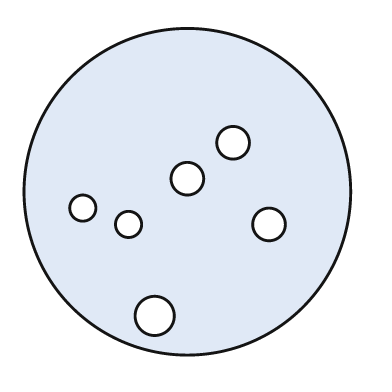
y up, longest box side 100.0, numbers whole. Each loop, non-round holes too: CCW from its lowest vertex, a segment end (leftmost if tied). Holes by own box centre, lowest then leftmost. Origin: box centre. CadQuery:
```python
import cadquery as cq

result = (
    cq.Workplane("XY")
    .moveTo(0.0, 0.0)
    .circle(50.0)
    .moveTo(-10.0, -38.0)
    .circle(6.0)
    .moveTo(-18.0, -10.0)
    .circle(4.0)
    .moveTo(25.0, -10.0)
    .circle(5.0)
    .moveTo(-32.0, -5.0)
    .circle(4.0)
    .moveTo(0.0, 4.0)
    .circle(5.0)
    .moveTo(14.0, 15.0)
    .circle(5.0)
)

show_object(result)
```